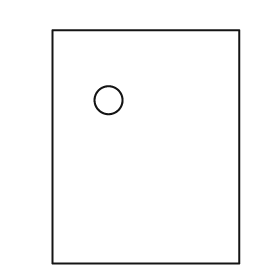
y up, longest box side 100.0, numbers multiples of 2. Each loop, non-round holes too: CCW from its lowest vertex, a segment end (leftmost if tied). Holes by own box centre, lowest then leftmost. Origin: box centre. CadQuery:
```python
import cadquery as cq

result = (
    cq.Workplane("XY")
    .moveTo(-40.0, -50.0)
    .lineTo(40.0, -50.0)
    .lineTo(40.0, 50.0)
    .lineTo(-40.0, 50.0)
    .close()
    .moveTo(-16.0, 20.0)
    .circle(6.0)
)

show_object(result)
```